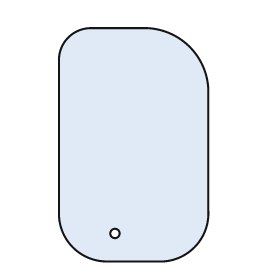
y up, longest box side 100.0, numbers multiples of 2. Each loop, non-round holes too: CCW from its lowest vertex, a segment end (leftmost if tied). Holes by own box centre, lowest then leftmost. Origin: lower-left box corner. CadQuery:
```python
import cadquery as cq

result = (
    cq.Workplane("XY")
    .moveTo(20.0, 0.0)
    .lineTo(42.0, 0.0)
    .threePointArc((58.0, 6.0), (64.0, 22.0))
    .lineTo(64.0, 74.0)
    .threePointArc((56.0, 92.0), (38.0, 100.0))
    .lineTo(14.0, 100.0)
    .threePointArc((4.0, 96.0), (0.0, 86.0))
    .lineTo(0.0, 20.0)
    .threePointArc((6.0, 6.0), (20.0, 0.0))
    .close()
    .moveTo(24.0, 12.0)
    .circle(2.0)
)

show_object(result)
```